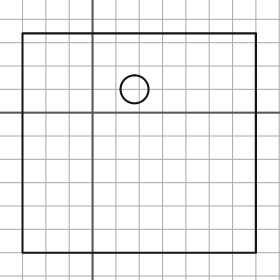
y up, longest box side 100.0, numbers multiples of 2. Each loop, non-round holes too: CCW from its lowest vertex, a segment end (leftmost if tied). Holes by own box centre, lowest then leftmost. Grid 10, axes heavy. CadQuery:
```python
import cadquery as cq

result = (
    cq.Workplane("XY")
    .moveTo(-30.0, -60.0)
    .lineTo(70.0, -60.0)
    .lineTo(70.0, 34.0)
    .lineTo(-30.0, 34.0)
    .close()
    .moveTo(18.0, 10.0)
    .circle(6.0)
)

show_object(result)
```